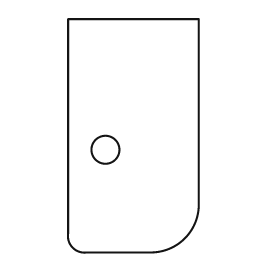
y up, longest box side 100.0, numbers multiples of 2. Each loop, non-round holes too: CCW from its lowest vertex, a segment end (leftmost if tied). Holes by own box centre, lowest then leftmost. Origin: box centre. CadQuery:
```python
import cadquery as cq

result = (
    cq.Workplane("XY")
    .moveTo(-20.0, -50.0)
    .lineTo(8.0, -50.0)
    .threePointArc((22.0, -44.0), (28.0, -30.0))
    .lineTo(28.0, 50.0)
    .lineTo(-28.0, 50.0)
    .lineTo(-28.0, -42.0)
    .threePointArc((-26.0, -48.0), (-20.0, -50.0))
    .close()
    .moveTo(-12.0, -6.0)
    .circle(6.0)
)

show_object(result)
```